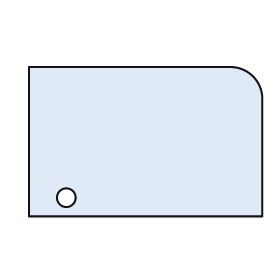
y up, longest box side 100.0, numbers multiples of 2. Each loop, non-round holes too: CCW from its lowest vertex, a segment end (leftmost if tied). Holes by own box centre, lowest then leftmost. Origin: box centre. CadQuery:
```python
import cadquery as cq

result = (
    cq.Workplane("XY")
    .moveTo(-50.0, -32.0)
    .lineTo(50.0, -32.0)
    .lineTo(50.0, 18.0)
    .threePointArc((46.0, 28.0), (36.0, 32.0))
    .lineTo(-50.0, 32.0)
    .close()
    .moveTo(-34.0, -24.0)
    .circle(4.0)
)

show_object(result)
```